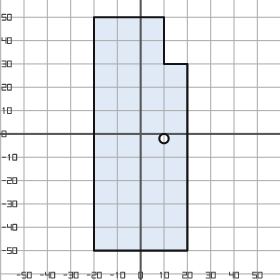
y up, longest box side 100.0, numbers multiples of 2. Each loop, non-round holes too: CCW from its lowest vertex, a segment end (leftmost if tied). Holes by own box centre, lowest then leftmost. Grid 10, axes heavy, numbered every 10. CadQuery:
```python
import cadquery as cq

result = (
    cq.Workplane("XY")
    .moveTo(-20.0, -50.0)
    .lineTo(20.0, -50.0)
    .lineTo(20.0, 30.0)
    .lineTo(10.0, 30.0)
    .lineTo(10.0, 50.0)
    .lineTo(-20.0, 50.0)
    .close()
    .moveTo(10.0, -2.0)
    .circle(2.0)
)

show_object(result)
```